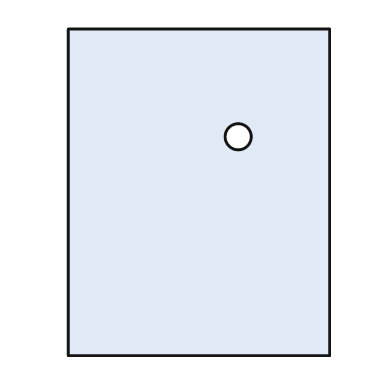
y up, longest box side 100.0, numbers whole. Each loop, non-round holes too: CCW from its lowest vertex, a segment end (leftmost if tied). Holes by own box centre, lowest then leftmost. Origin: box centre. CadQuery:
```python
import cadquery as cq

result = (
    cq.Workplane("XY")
    .moveTo(-40.0, -50.0)
    .lineTo(40.0, -50.0)
    .lineTo(40.0, 50.0)
    .lineTo(-40.0, 50.0)
    .close()
    .moveTo(12.0, 17.0)
    .circle(4.0)
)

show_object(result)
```